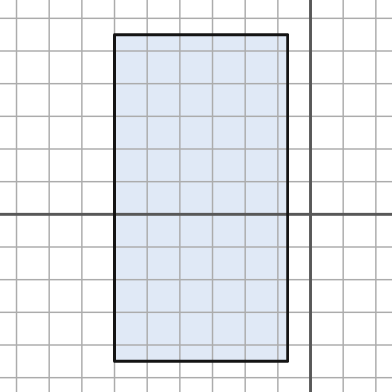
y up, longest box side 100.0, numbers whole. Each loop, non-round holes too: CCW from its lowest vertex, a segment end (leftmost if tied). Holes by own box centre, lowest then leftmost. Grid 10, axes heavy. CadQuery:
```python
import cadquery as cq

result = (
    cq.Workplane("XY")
    .moveTo(-60.0, -45.0)
    .lineTo(-7.0, -45.0)
    .lineTo(-7.0, 55.0)
    .lineTo(-60.0, 55.0)
    .close()
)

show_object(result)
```